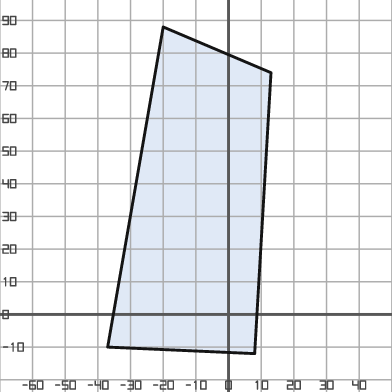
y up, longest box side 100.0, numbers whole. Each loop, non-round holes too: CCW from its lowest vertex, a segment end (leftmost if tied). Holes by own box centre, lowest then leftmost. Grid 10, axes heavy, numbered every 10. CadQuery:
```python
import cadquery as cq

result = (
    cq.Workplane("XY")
    .moveTo(8.0, -12.0)
    .lineTo(13.0, 74.0)
    .lineTo(-20.0, 88.0)
    .lineTo(-37.0, -10.0)
    .close()
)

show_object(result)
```